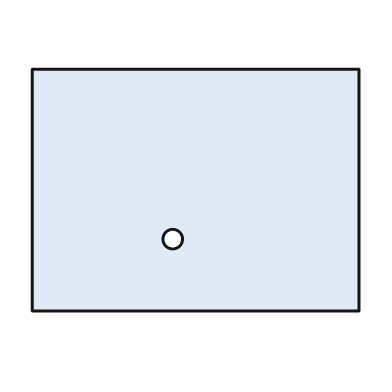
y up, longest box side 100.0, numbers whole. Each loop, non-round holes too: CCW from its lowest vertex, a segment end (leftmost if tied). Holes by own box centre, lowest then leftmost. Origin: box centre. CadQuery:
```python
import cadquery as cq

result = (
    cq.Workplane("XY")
    .moveTo(-50.0, -37.0)
    .lineTo(50.0, -37.0)
    .lineTo(50.0, 37.0)
    .lineTo(-50.0, 37.0)
    .close()
    .moveTo(-7.0, -15.0)
    .circle(3.0)
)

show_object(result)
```